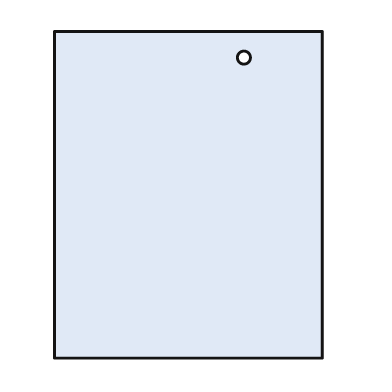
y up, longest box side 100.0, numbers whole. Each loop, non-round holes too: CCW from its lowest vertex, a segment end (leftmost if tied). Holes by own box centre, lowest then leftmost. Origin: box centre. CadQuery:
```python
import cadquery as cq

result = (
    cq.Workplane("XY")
    .moveTo(-41.0, -50.0)
    .lineTo(41.0, -50.0)
    .lineTo(41.0, 50.0)
    .lineTo(-41.0, 50.0)
    .close()
    .moveTo(17.0, 42.0)
    .circle(2.0)
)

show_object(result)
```